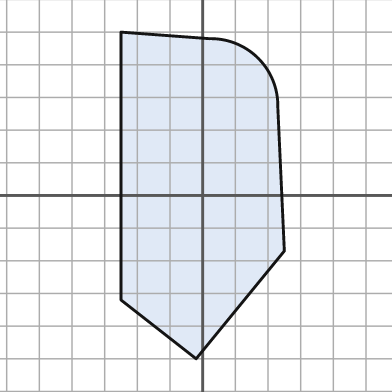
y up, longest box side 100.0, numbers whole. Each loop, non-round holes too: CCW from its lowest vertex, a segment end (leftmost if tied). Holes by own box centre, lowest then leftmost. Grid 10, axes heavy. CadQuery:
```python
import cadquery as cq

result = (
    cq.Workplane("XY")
    .moveTo(-2.0, -50.0)
    .lineTo(25.0, -17.0)
    .lineTo(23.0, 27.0)
    .threePointArc((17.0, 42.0), (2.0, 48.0))
    .lineTo(-25.0, 50.0)
    .lineTo(-25.0, -32.0)
    .close()
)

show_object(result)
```